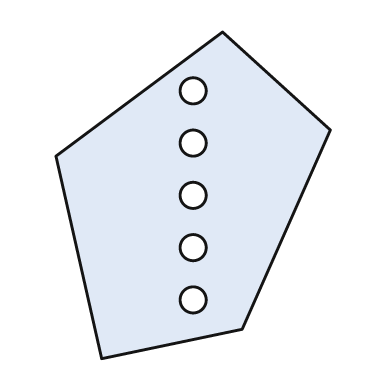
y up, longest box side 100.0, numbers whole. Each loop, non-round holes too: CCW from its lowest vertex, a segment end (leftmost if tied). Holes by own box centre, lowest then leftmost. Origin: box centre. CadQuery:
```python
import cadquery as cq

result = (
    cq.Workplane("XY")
    .moveTo(-28.0, -50.0)
    .lineTo(15.0, -41.0)
    .lineTo(42.0, 20.0)
    .lineTo(9.0, 50.0)
    .lineTo(-42.0, 12.0)
    .close()
    .moveTo(0.0, -32.0)
    .circle(4.0)
    .moveTo(0.0, -16.0)
    .circle(4.0)
    .moveTo(0.0, 0.0)
    .circle(4.0)
    .moveTo(0.0, 16.0)
    .circle(4.0)
    .moveTo(0.0, 32.0)
    .circle(4.0)
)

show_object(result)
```